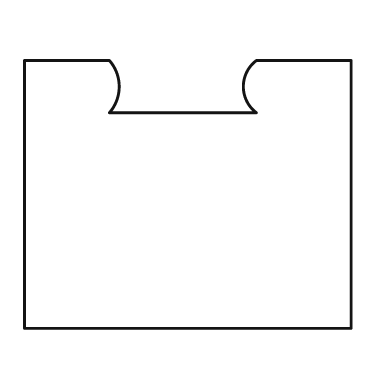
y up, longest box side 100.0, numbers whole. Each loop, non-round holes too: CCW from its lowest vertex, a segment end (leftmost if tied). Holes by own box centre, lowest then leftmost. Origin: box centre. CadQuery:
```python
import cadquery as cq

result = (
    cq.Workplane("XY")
    .moveTo(-50.0, -41.0)
    .lineTo(50.0, -41.0)
    .lineTo(50.0, 41.0)
    .lineTo(21.0, 41.0)
    .threePointArc((17.0, 33.0), (21.0, 25.0))
    .lineTo(-24.0, 25.0)
    .threePointArc((-21.0, 33.0), (-24.0, 41.0))
    .lineTo(-50.0, 41.0)
    .close()
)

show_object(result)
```